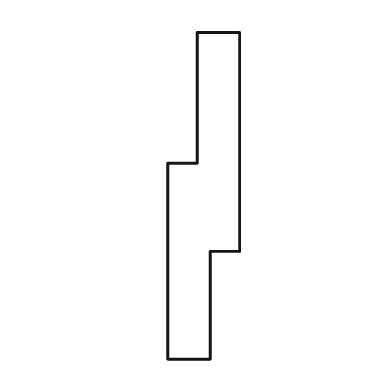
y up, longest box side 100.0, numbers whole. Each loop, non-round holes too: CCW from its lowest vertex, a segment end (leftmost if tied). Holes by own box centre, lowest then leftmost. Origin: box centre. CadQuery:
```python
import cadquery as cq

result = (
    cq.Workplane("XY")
    .moveTo(-11.0, -50.0)
    .lineTo(2.0, -50.0)
    .lineTo(2.0, -17.0)
    .lineTo(11.0, -17.0)
    .lineTo(11.0, 50.0)
    .lineTo(-2.0, 50.0)
    .lineTo(-2.0, 10.0)
    .lineTo(-11.0, 10.0)
    .close()
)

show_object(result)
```